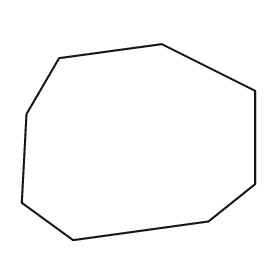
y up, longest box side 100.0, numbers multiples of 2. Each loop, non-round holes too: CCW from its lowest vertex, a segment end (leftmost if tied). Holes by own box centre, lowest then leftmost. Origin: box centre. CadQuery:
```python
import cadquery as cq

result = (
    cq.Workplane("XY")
    .moveTo(-28.0, -42.0)
    .lineTo(30.0, -34.0)
    .lineTo(50.0, -18.0)
    .lineTo(50.0, 22.0)
    .lineTo(10.0, 42.0)
    .lineTo(-34.0, 36.0)
    .lineTo(-48.0, 12.0)
    .lineTo(-50.0, -26.0)
    .close()
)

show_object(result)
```